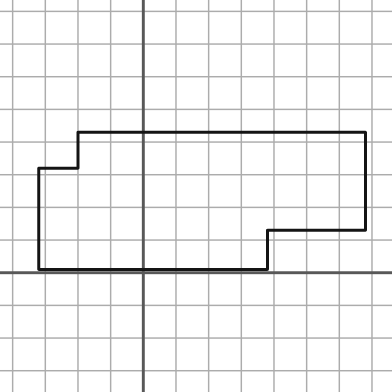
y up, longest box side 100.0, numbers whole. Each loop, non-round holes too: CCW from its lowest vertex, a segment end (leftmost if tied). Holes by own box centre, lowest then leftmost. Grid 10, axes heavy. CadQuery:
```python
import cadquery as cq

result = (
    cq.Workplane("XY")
    .moveTo(-32.0, 1.0)
    .lineTo(38.0, 1.0)
    .lineTo(38.0, 13.0)
    .lineTo(68.0, 13.0)
    .lineTo(68.0, 43.0)
    .lineTo(-20.0, 43.0)
    .lineTo(-20.0, 32.0)
    .lineTo(-32.0, 32.0)
    .close()
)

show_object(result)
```